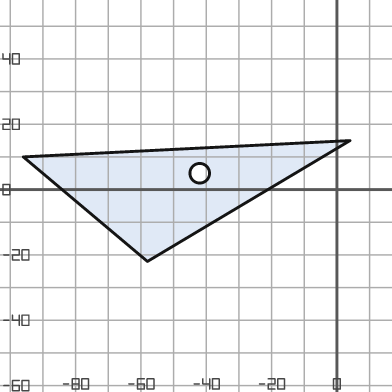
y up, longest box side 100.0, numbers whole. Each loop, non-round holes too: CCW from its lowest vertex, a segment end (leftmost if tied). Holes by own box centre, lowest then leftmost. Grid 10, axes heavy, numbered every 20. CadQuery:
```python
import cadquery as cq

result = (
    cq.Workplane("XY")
    .moveTo(-58.0, -22.0)
    .lineTo(4.0, 15.0)
    .lineTo(-96.0, 10.0)
    .close()
    .moveTo(-42.0, 5.0)
    .circle(3.0)
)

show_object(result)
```